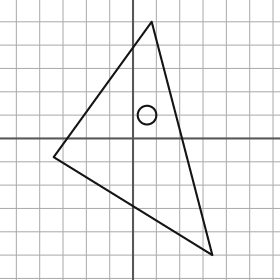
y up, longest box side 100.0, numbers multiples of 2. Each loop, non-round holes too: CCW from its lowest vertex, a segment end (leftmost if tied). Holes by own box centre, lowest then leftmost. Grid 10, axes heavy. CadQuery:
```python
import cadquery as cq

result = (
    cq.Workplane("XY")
    .moveTo(34.0, -50.0)
    .lineTo(8.0, 50.0)
    .lineTo(-34.0, -8.0)
    .close()
    .moveTo(6.0, 10.0)
    .circle(4.0)
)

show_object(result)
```